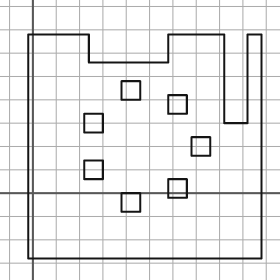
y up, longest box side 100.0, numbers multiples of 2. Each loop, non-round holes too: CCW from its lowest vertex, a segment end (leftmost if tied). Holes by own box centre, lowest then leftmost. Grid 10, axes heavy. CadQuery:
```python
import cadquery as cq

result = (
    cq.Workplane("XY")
    .moveTo(-2.0, -28.0)
    .lineTo(98.0, -28.0)
    .lineTo(98.0, 68.0)
    .lineTo(92.0, 68.0)
    .lineTo(92.0, 30.0)
    .lineTo(82.0, 30.0)
    .lineTo(82.0, 68.0)
    .lineTo(58.0, 68.0)
    .lineTo(58.0, 56.0)
    .lineTo(24.0, 56.0)
    .lineTo(24.0, 68.0)
    .lineTo(-2.0, 68.0)
    .close()
    .moveTo(38.0, -8.0)
    .lineTo(46.0, -8.0)
    .lineTo(46.0, 0.0)
    .lineTo(38.0, 0.0)
    .close()
    .moveTo(58.0, -2.0)
    .lineTo(66.0, -2.0)
    .lineTo(66.0, 6.0)
    .lineTo(58.0, 6.0)
    .close()
    .moveTo(22.0, 6.0)
    .lineTo(30.0, 6.0)
    .lineTo(30.0, 14.0)
    .lineTo(22.0, 14.0)
    .close()
    .moveTo(68.0, 16.0)
    .lineTo(76.0, 16.0)
    .lineTo(76.0, 24.0)
    .lineTo(68.0, 24.0)
    .close()
    .moveTo(22.0, 26.0)
    .lineTo(30.0, 26.0)
    .lineTo(30.0, 34.0)
    .lineTo(22.0, 34.0)
    .close()
    .moveTo(58.0, 34.0)
    .lineTo(66.0, 34.0)
    .lineTo(66.0, 42.0)
    .lineTo(58.0, 42.0)
    .close()
    .moveTo(38.0, 40.0)
    .lineTo(46.0, 40.0)
    .lineTo(46.0, 48.0)
    .lineTo(38.0, 48.0)
    .close()
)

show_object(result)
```